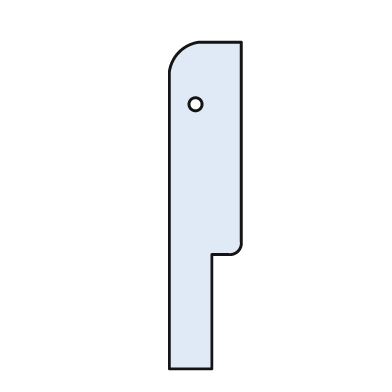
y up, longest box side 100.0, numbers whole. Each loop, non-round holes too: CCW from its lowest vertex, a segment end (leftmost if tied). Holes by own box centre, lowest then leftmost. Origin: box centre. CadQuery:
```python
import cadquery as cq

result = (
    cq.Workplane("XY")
    .moveTo(-11.0, -50.0)
    .lineTo(2.0, -50.0)
    .lineTo(2.0, -15.0)
    .lineTo(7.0, -15.0)
    .threePointArc((10.0, -14.0), (11.0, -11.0))
    .lineTo(11.0, 50.0)
    .lineTo(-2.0, 50.0)
    .threePointArc((-8.0, 47.0), (-11.0, 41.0))
    .close()
    .moveTo(-3.0, 31.0)
    .circle(2.0)
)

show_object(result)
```